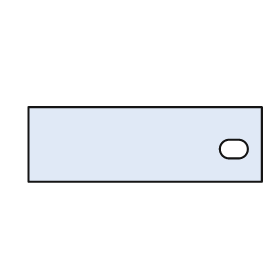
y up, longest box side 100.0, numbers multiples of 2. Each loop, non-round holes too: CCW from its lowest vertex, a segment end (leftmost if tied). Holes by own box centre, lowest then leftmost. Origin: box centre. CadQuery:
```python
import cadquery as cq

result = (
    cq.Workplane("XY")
    .moveTo(-50.0, -16.0)
    .lineTo(50.0, -16.0)
    .lineTo(50.0, 16.0)
    .lineTo(-50.0, 16.0)
    .close()
    .moveTo(36.0, -6.0)
    .lineTo(40.0, -6.0)
    .threePointArc((44.0, -2.0), (40.0, 2.0))
    .lineTo(36.0, 2.0)
    .threePointArc((32.0, -2.0), (36.0, -6.0))
    .close()
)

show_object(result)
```